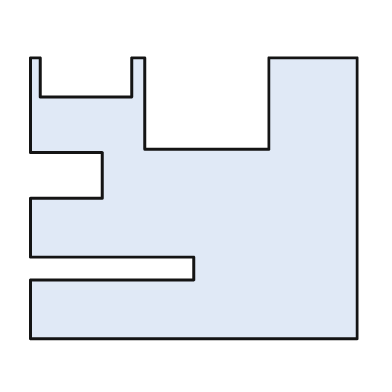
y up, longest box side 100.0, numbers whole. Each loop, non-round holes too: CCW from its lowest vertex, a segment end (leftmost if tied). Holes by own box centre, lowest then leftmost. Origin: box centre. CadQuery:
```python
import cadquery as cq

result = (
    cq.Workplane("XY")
    .moveTo(-50.0, -43.0)
    .lineTo(50.0, -43.0)
    .lineTo(50.0, 43.0)
    .lineTo(23.0, 43.0)
    .lineTo(23.0, 15.0)
    .lineTo(-15.0, 15.0)
    .lineTo(-15.0, 43.0)
    .lineTo(-19.0, 43.0)
    .lineTo(-19.0, 31.0)
    .lineTo(-47.0, 31.0)
    .lineTo(-47.0, 43.0)
    .lineTo(-50.0, 43.0)
    .lineTo(-50.0, 14.0)
    .lineTo(-28.0, 14.0)
    .lineTo(-28.0, 0.0)
    .lineTo(-50.0, 0.0)
    .lineTo(-50.0, -18.0)
    .lineTo(0.0, -18.0)
    .lineTo(0.0, -25.0)
    .lineTo(-50.0, -25.0)
    .close()
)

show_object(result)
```